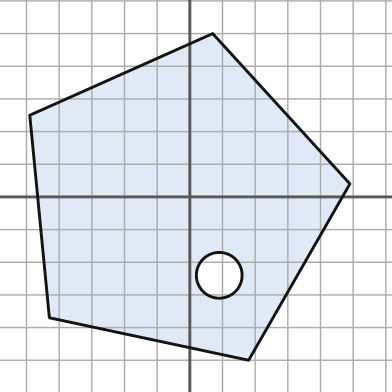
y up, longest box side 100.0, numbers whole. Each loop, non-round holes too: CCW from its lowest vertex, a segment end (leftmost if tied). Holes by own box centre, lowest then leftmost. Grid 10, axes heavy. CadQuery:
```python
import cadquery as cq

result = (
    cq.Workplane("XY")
    .moveTo(18.0, -50.0)
    .lineTo(49.0, 4.0)
    .lineTo(7.0, 50.0)
    .lineTo(-49.0, 25.0)
    .lineTo(-43.0, -37.0)
    .close()
    .moveTo(9.0, -24.0)
    .circle(7.0)
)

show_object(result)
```